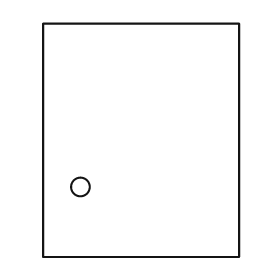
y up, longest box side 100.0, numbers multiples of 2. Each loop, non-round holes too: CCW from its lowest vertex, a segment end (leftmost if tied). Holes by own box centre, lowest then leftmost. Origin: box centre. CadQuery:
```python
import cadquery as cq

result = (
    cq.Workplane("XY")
    .moveTo(-42.0, -50.0)
    .lineTo(42.0, -50.0)
    .lineTo(42.0, 50.0)
    .lineTo(-42.0, 50.0)
    .close()
    .moveTo(-26.0, -20.0)
    .circle(4.0)
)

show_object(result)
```